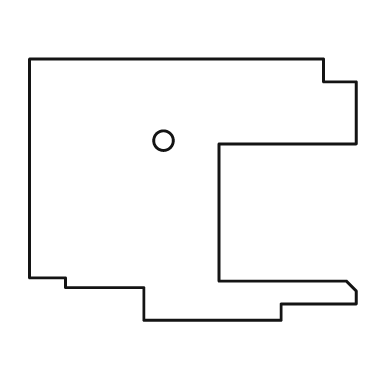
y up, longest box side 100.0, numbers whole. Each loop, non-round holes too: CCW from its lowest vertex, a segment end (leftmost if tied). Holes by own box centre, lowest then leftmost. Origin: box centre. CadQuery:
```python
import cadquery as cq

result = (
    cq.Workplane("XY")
    .moveTo(-15.0, -40.0)
    .lineTo(27.0, -40.0)
    .lineTo(27.0, -35.0)
    .lineTo(50.0, -35.0)
    .lineTo(50.0, -31.0)
    .lineTo(47.0, -28.0)
    .lineTo(8.0, -28.0)
    .lineTo(8.0, 14.0)
    .lineTo(50.0, 14.0)
    .lineTo(50.0, 33.0)
    .lineTo(40.0, 33.0)
    .lineTo(40.0, 40.0)
    .lineTo(-50.0, 40.0)
    .lineTo(-50.0, -27.0)
    .lineTo(-39.0, -27.0)
    .lineTo(-39.0, -30.0)
    .lineTo(-15.0, -30.0)
    .close()
    .moveTo(-9.0, 15.0)
    .circle(3.0)
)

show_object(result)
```